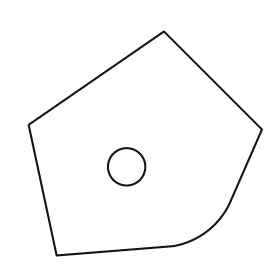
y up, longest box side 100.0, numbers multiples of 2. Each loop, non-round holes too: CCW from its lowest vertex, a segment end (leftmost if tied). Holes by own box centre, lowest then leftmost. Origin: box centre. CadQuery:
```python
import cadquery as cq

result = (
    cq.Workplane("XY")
    .moveTo(-38.0, -48.0)
    .lineTo(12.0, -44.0)
    .threePointArc((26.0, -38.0), (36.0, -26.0))
    .lineTo(50.0, 6.0)
    .lineTo(8.0, 48.0)
    .lineTo(-50.0, 8.0)
    .close()
    .moveTo(-8.0, -10.0)
    .circle(8.0)
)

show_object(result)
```